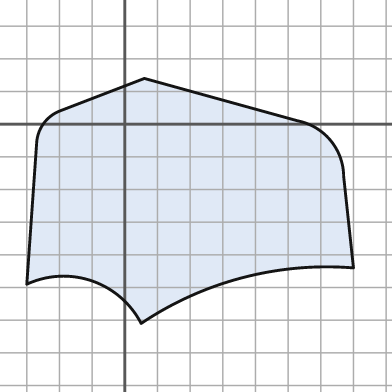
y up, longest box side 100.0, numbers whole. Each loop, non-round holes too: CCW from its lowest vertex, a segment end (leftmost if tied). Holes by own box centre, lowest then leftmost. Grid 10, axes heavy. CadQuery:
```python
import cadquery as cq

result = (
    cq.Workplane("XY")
    .moveTo(5.0, -61.0)
    .threePointArc((36.0, -47.0), (70.0, -44.0))
    .lineTo(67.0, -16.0)
    .threePointArc((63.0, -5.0), (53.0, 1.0))
    .lineTo(6.0, 14.0)
    .lineTo(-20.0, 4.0)
    .threePointArc((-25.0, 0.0), (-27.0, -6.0))
    .lineTo(-30.0, -49.0)
    .threePointArc((-10.0, -48.0), (5.0, -61.0))
    .close()
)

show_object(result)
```